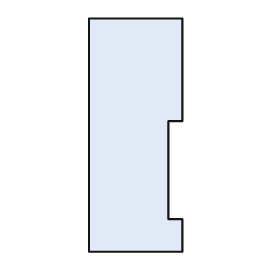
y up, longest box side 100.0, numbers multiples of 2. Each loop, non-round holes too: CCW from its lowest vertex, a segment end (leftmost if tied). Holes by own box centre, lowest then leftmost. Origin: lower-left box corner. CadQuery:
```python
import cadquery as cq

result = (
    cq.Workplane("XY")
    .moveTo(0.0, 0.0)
    .lineTo(40.0, 0.0)
    .lineTo(40.0, 14.0)
    .lineTo(34.0, 14.0)
    .lineTo(34.0, 56.0)
    .lineTo(40.0, 56.0)
    .lineTo(40.0, 100.0)
    .lineTo(0.0, 100.0)
    .close()
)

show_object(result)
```